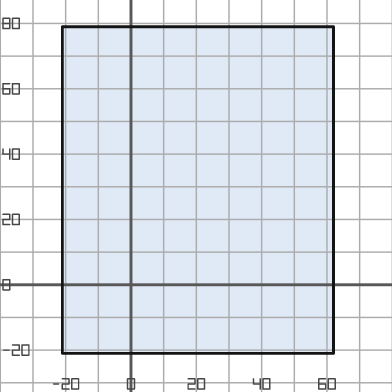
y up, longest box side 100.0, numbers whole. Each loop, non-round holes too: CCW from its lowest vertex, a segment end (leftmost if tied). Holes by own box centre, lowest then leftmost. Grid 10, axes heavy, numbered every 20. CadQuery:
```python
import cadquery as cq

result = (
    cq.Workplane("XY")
    .moveTo(-21.0, -21.0)
    .lineTo(62.0, -21.0)
    .lineTo(62.0, 79.0)
    .lineTo(-21.0, 79.0)
    .close()
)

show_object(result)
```